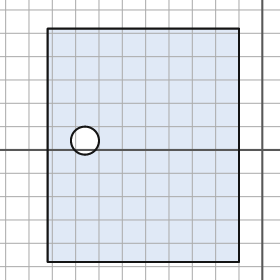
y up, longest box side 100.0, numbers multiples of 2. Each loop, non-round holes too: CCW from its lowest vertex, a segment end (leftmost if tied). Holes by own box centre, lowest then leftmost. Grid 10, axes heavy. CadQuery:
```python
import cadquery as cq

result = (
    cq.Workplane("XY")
    .moveTo(-92.0, -48.0)
    .lineTo(-10.0, -48.0)
    .lineTo(-10.0, 52.0)
    .lineTo(-92.0, 52.0)
    .close()
    .moveTo(-76.0, 4.0)
    .circle(6.0)
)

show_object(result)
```